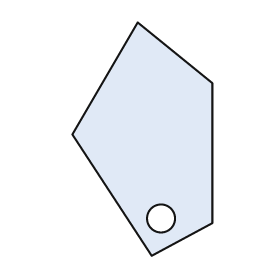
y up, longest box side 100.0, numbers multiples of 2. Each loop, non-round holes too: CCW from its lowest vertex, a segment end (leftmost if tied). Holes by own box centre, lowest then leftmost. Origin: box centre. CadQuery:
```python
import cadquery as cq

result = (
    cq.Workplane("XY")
    .moveTo(4.0, -50.0)
    .lineTo(30.0, -36.0)
    .lineTo(30.0, 24.0)
    .lineTo(-2.0, 50.0)
    .lineTo(-30.0, 2.0)
    .close()
    .moveTo(8.0, -34.0)
    .circle(6.0)
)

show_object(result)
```